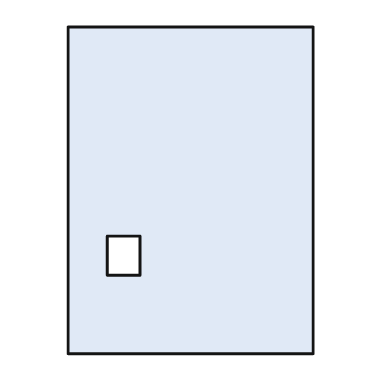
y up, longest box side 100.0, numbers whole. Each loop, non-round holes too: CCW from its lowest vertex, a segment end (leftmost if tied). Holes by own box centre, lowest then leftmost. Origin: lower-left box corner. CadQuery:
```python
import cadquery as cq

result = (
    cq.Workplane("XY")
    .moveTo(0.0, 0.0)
    .lineTo(75.0, 0.0)
    .lineTo(75.0, 100.0)
    .lineTo(0.0, 100.0)
    .close()
    .moveTo(12.0, 24.0)
    .lineTo(22.0, 24.0)
    .lineTo(22.0, 36.0)
    .lineTo(12.0, 36.0)
    .close()
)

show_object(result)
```